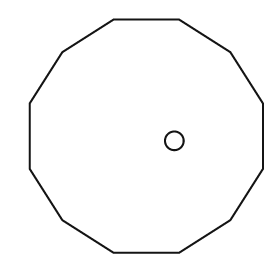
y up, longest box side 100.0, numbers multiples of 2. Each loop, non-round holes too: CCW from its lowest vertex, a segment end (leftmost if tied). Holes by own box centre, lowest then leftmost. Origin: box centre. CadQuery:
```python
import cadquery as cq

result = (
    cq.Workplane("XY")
    .moveTo(-14.0, -50.0)
    .lineTo(14.0, -50.0)
    .lineTo(36.0, -36.0)
    .lineTo(50.0, -14.0)
    .lineTo(50.0, 14.0)
    .lineTo(36.0, 36.0)
    .lineTo(14.0, 50.0)
    .lineTo(-14.0, 50.0)
    .lineTo(-36.0, 36.0)
    .lineTo(-50.0, 14.0)
    .lineTo(-50.0, -14.0)
    .lineTo(-36.0, -36.0)
    .close()
    .moveTo(12.0, -2.0)
    .circle(4.0)
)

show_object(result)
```